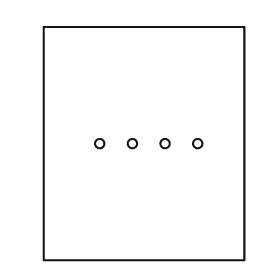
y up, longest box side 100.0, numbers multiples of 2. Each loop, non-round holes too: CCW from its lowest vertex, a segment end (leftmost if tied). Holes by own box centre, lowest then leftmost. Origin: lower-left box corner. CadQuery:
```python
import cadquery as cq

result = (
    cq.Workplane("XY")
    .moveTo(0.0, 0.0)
    .lineTo(86.0, 0.0)
    .lineTo(86.0, 100.0)
    .lineTo(0.0, 100.0)
    .close()
    .moveTo(24.0, 50.0)
    .circle(2.0)
    .moveTo(38.0, 50.0)
    .circle(2.0)
    .moveTo(52.0, 50.0)
    .circle(2.0)
    .moveTo(66.0, 50.0)
    .circle(2.0)
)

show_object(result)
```